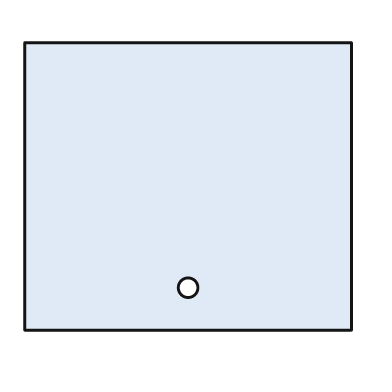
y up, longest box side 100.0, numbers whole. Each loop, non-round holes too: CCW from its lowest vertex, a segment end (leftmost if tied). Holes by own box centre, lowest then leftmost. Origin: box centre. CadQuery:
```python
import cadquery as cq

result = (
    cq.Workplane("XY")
    .moveTo(-50.0, -44.0)
    .lineTo(50.0, -44.0)
    .lineTo(50.0, 44.0)
    .lineTo(-50.0, 44.0)
    .close()
    .moveTo(0.0, -31.0)
    .circle(3.0)
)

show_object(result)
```